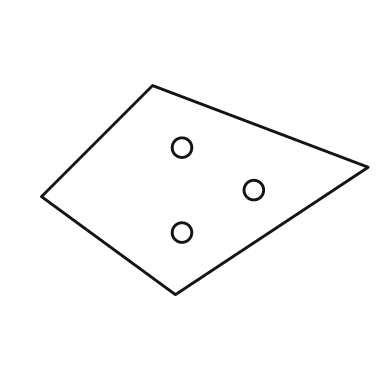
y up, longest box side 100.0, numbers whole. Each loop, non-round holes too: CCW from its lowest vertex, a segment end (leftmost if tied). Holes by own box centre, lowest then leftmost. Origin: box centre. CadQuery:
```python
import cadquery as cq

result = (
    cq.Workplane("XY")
    .moveTo(-9.0, -32.0)
    .lineTo(50.0, 7.0)
    .lineTo(-16.0, 32.0)
    .lineTo(-50.0, -2.0)
    .close()
    .moveTo(-7.0, -13.0)
    .circle(3.0)
    .moveTo(15.0, 0.0)
    .circle(3.0)
    .moveTo(-7.0, 13.0)
    .circle(3.0)
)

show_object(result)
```